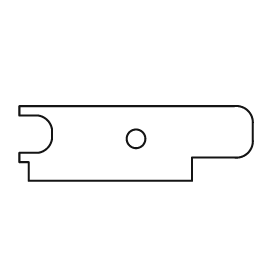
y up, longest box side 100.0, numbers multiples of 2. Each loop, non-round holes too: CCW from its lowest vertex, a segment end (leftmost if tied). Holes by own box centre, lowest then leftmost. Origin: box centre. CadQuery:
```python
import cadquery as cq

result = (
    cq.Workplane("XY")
    .moveTo(-46.0, -16.0)
    .lineTo(24.0, -16.0)
    .lineTo(24.0, -6.0)
    .lineTo(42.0, -6.0)
    .threePointArc((48.0, -4.0), (50.0, 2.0))
    .lineTo(50.0, 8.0)
    .threePointArc((48.0, 14.0), (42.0, 16.0))
    .lineTo(-50.0, 16.0)
    .lineTo(-50.0, 12.0)
    .lineTo(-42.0, 12.0)
    .threePointArc((-38.0, 10.0), (-36.0, 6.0))
    .lineTo(-36.0, 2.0)
    .threePointArc((-38.0, -2.0), (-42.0, -4.0))
    .lineTo(-50.0, -4.0)
    .lineTo(-50.0, -8.0)
    .lineTo(-46.0, -8.0)
    .close()
    .moveTo(0.0, 2.0)
    .circle(4.0)
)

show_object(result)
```